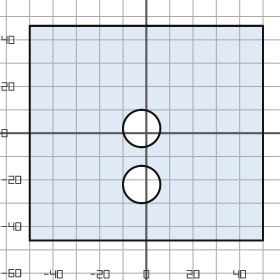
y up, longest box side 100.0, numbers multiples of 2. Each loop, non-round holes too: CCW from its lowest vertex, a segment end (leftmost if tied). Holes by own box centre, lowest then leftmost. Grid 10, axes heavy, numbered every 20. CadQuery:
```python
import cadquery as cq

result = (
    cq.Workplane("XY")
    .moveTo(-50.0, -46.0)
    .lineTo(50.0, -46.0)
    .lineTo(50.0, 46.0)
    .lineTo(-50.0, 46.0)
    .close()
    .moveTo(-2.0, -22.0)
    .circle(8.0)
    .moveTo(-2.0, 2.0)
    .circle(8.0)
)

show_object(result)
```